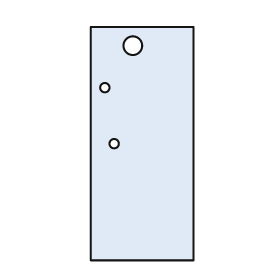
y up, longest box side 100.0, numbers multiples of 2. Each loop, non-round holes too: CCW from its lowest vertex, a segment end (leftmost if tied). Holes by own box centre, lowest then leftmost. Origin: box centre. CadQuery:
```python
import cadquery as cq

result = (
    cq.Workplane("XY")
    .moveTo(-22.0, -50.0)
    .lineTo(22.0, -50.0)
    .lineTo(22.0, 50.0)
    .lineTo(-22.0, 50.0)
    .close()
    .moveTo(-12.0, 0.0)
    .circle(2.0)
    .moveTo(-16.0, 24.0)
    .circle(2.0)
    .moveTo(-4.0, 42.0)
    .circle(4.0)
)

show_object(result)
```